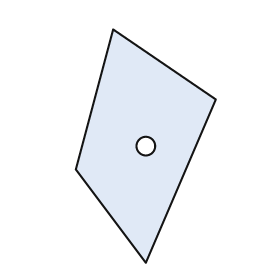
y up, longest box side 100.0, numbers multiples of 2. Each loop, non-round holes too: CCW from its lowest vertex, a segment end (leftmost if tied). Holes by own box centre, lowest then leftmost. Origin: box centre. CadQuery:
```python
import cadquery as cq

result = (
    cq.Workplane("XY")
    .moveTo(0.0, -50.0)
    .lineTo(30.0, 20.0)
    .lineTo(-14.0, 50.0)
    .lineTo(-30.0, -10.0)
    .close()
    .moveTo(0.0, 0.0)
    .circle(4.0)
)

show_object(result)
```